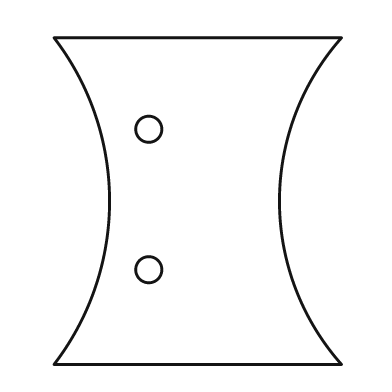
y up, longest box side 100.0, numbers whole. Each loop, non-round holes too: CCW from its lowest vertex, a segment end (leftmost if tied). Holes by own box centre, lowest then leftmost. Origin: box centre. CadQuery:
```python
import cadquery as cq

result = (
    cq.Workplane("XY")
    .moveTo(-44.0, -50.0)
    .lineTo(44.0, -50.0)
    .threePointArc((25.0, 0.0), (44.0, 50.0))
    .lineTo(-44.0, 50.0)
    .threePointArc((-27.0, 0.0), (-44.0, -50.0))
    .close()
    .moveTo(-15.0, -21.0)
    .circle(4.0)
    .moveTo(-15.0, 22.0)
    .circle(4.0)
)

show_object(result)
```